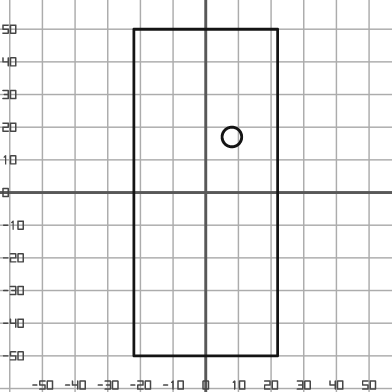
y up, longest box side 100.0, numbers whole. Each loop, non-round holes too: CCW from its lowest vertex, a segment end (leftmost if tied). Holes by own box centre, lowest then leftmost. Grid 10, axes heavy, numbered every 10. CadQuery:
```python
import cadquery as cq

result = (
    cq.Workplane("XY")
    .moveTo(-22.0, -50.0)
    .lineTo(22.0, -50.0)
    .lineTo(22.0, 50.0)
    .lineTo(-22.0, 50.0)
    .close()
    .moveTo(8.0, 17.0)
    .circle(3.0)
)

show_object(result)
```